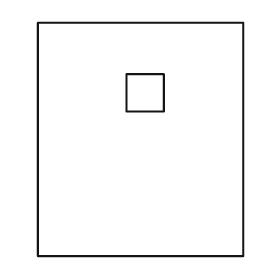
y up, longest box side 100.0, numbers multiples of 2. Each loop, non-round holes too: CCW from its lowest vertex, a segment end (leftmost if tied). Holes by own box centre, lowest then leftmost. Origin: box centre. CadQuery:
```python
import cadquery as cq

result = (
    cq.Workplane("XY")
    .moveTo(-44.0, -50.0)
    .lineTo(44.0, -50.0)
    .lineTo(44.0, 50.0)
    .lineTo(-44.0, 50.0)
    .close()
    .moveTo(-6.0, 12.0)
    .lineTo(10.0, 12.0)
    .lineTo(10.0, 28.0)
    .lineTo(-6.0, 28.0)
    .close()
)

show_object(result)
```